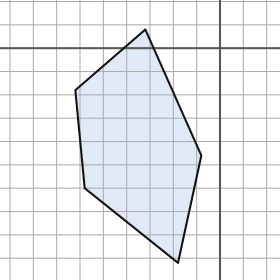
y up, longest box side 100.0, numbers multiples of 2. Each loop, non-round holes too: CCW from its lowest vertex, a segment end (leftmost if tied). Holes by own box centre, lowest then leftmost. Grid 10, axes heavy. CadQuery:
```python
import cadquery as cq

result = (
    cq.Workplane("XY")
    .moveTo(-18.0, -92.0)
    .lineTo(-8.0, -46.0)
    .lineTo(-32.0, 8.0)
    .lineTo(-62.0, -18.0)
    .lineTo(-58.0, -60.0)
    .close()
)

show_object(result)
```